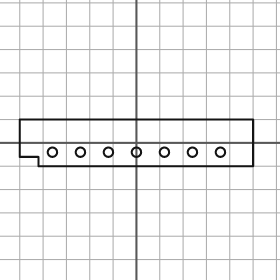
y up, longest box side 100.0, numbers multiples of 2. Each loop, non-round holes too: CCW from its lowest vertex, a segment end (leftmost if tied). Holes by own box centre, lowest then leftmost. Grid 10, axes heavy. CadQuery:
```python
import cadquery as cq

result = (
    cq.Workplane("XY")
    .moveTo(-42.0, -10.0)
    .lineTo(50.0, -10.0)
    .lineTo(50.0, 10.0)
    .lineTo(-50.0, 10.0)
    .lineTo(-50.0, -6.0)
    .lineTo(-42.0, -6.0)
    .close()
    .moveTo(-36.0, -4.0)
    .circle(2.0)
    .moveTo(-24.0, -4.0)
    .circle(2.0)
    .moveTo(-12.0, -4.0)
    .circle(2.0)
    .moveTo(0.0, -4.0)
    .circle(2.0)
    .moveTo(12.0, -4.0)
    .circle(2.0)
    .moveTo(24.0, -4.0)
    .circle(2.0)
    .moveTo(36.0, -4.0)
    .circle(2.0)
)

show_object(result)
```